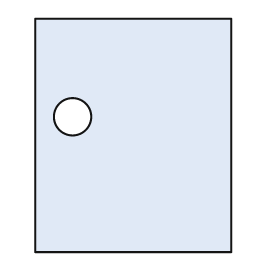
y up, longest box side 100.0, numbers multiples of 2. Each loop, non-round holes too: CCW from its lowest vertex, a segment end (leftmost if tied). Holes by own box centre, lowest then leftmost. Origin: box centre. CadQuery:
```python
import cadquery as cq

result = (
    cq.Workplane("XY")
    .moveTo(-42.0, -50.0)
    .lineTo(42.0, -50.0)
    .lineTo(42.0, 50.0)
    .lineTo(-42.0, 50.0)
    .close()
    .moveTo(-26.0, 8.0)
    .circle(8.0)
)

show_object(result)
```